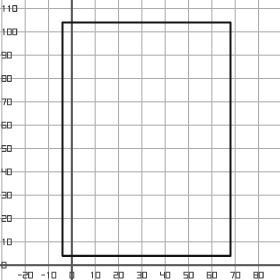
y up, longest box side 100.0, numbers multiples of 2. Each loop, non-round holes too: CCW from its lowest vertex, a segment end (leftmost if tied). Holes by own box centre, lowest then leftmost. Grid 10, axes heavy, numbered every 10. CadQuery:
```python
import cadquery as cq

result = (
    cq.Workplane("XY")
    .moveTo(-4.0, 4.0)
    .lineTo(68.0, 4.0)
    .lineTo(68.0, 104.0)
    .lineTo(-4.0, 104.0)
    .close()
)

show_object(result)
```